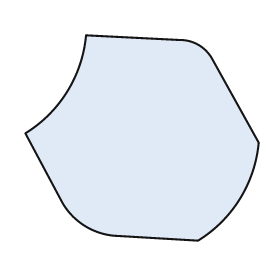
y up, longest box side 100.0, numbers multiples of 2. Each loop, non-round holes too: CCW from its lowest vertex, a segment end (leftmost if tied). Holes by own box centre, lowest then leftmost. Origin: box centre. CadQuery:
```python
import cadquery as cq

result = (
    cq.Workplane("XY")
    .moveTo(24.0, -44.0)
    .threePointArc((42.0, -26.0), (50.0, -2.0))
    .lineTo(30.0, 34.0)
    .threePointArc((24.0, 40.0), (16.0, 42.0))
    .lineTo(-24.0, 44.0)
    .threePointArc((-32.0, 20.0), (-50.0, 2.0))
    .lineTo(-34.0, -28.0)
    .threePointArc((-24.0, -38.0), (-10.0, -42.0))
    .close()
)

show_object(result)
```